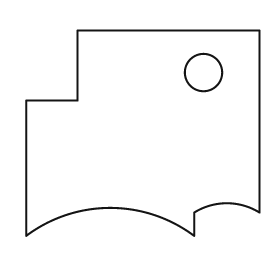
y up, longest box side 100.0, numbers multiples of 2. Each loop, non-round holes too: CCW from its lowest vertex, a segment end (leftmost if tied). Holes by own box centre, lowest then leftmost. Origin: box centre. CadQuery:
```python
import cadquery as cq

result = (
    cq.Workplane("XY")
    .moveTo(-50.0, -44.0)
    .threePointArc((-14.0, -32.0), (22.0, -44.0))
    .lineTo(22.0, -34.0)
    .threePointArc((36.0, -30.0), (50.0, -34.0))
    .lineTo(50.0, 44.0)
    .lineTo(-28.0, 44.0)
    .lineTo(-28.0, 14.0)
    .lineTo(-50.0, 14.0)
    .close()
    .moveTo(26.0, 26.0)
    .circle(8.0)
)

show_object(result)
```